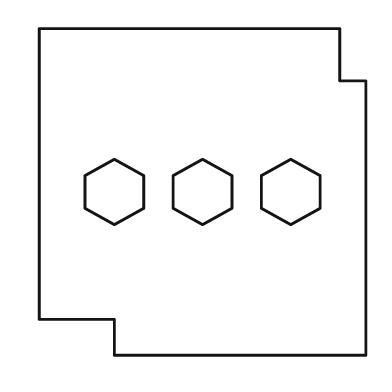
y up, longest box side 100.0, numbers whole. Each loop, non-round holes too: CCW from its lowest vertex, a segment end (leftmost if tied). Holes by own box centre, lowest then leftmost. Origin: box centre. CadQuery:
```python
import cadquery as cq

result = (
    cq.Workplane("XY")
    .moveTo(-27.0, -50.0)
    .lineTo(50.0, -50.0)
    .lineTo(50.0, 34.0)
    .lineTo(42.0, 34.0)
    .lineTo(42.0, 50.0)
    .lineTo(-50.0, 50.0)
    .lineTo(-50.0, -39.0)
    .lineTo(-27.0, -39.0)
    .close()
    .moveTo(-27.0, -10.0)
    .lineTo(-18.0, -5.0)
    .lineTo(-18.0, 5.0)
    .lineTo(-27.0, 10.0)
    .lineTo(-36.0, 5.0)
    .lineTo(-36.0, -5.0)
    .close()
    .moveTo(0.0, -10.0)
    .lineTo(9.0, -5.0)
    .lineTo(9.0, 5.0)
    .lineTo(0.0, 10.0)
    .lineTo(-9.0, 5.0)
    .lineTo(-9.0, -5.0)
    .close()
    .moveTo(27.0, -10.0)
    .lineTo(36.0, -5.0)
    .lineTo(36.0, 5.0)
    .lineTo(27.0, 10.0)
    .lineTo(18.0, 5.0)
    .lineTo(18.0, -5.0)
    .close()
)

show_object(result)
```